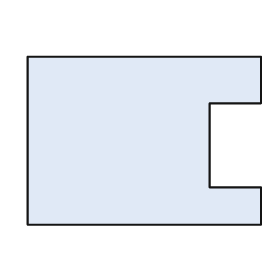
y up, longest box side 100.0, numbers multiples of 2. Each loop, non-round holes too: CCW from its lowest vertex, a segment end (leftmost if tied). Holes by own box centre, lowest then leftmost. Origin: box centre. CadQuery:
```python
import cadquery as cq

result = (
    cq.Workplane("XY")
    .moveTo(-50.0, -36.0)
    .lineTo(50.0, -36.0)
    .lineTo(50.0, -20.0)
    .lineTo(28.0, -20.0)
    .lineTo(28.0, 16.0)
    .lineTo(50.0, 16.0)
    .lineTo(50.0, 36.0)
    .lineTo(-50.0, 36.0)
    .close()
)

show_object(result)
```